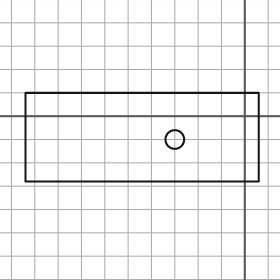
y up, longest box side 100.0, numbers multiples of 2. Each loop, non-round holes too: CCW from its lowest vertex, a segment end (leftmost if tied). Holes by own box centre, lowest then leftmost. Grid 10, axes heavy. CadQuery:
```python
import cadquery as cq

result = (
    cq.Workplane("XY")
    .moveTo(-94.0, -28.0)
    .lineTo(6.0, -28.0)
    .lineTo(6.0, 10.0)
    .lineTo(-94.0, 10.0)
    .close()
    .moveTo(-30.0, -10.0)
    .circle(4.0)
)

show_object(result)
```